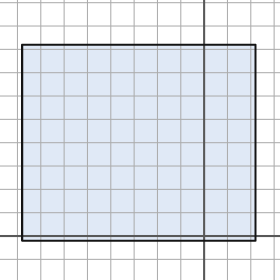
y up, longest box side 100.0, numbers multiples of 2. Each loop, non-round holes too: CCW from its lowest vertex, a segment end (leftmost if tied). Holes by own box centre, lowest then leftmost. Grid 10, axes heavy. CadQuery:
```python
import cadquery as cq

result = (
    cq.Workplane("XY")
    .moveTo(-78.0, -2.0)
    .lineTo(22.0, -2.0)
    .lineTo(22.0, 82.0)
    .lineTo(-78.0, 82.0)
    .close()
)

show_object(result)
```